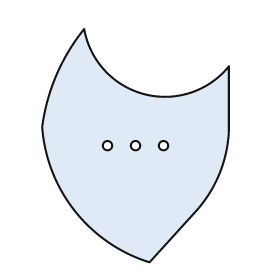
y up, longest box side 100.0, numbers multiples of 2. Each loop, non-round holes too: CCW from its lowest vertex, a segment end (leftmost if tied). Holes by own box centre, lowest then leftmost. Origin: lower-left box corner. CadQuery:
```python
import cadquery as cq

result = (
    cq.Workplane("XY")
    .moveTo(46.0, 0.0)
    .lineTo(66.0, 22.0)
    .threePointArc((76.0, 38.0), (80.0, 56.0))
    .lineTo(80.0, 84.0)
    .threePointArc((44.0, 72.0), (18.0, 100.0))
    .threePointArc((6.0, 80.0), (0.0, 58.0))
    .threePointArc((14.0, 22.0), (46.0, 0.0))
    .close()
    .moveTo(28.0, 50.0)
    .circle(2.0)
    .moveTo(40.0, 50.0)
    .circle(2.0)
    .moveTo(52.0, 50.0)
    .circle(2.0)
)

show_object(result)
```